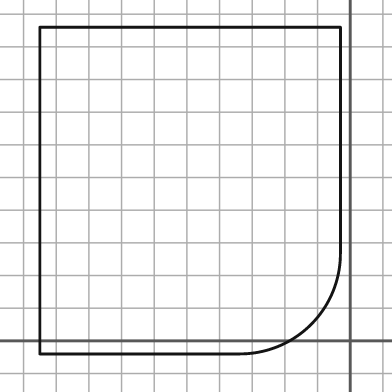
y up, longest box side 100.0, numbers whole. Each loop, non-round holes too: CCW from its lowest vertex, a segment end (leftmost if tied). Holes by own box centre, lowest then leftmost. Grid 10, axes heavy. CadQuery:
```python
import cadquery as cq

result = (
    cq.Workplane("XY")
    .moveTo(-95.0, -4.0)
    .lineTo(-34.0, -4.0)
    .threePointArc((-12.0, 5.0), (-3.0, 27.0))
    .lineTo(-3.0, 96.0)
    .lineTo(-95.0, 96.0)
    .close()
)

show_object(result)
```